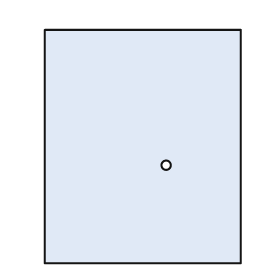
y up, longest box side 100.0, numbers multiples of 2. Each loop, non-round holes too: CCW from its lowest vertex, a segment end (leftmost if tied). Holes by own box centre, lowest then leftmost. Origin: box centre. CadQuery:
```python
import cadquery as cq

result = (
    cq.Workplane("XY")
    .moveTo(-42.0, -50.0)
    .lineTo(42.0, -50.0)
    .lineTo(42.0, 50.0)
    .lineTo(-42.0, 50.0)
    .close()
    .moveTo(10.0, -8.0)
    .circle(2.0)
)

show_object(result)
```